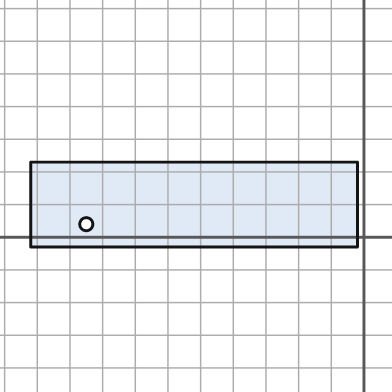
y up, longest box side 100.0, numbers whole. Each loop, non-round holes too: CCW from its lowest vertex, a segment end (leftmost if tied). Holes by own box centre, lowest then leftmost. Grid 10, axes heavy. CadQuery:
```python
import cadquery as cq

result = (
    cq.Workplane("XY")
    .moveTo(-102.0, -3.0)
    .lineTo(-2.0, -3.0)
    .lineTo(-2.0, 23.0)
    .lineTo(-102.0, 23.0)
    .close()
    .moveTo(-85.0, 4.0)
    .circle(2.0)
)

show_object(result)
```